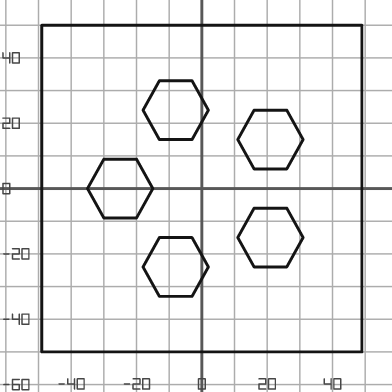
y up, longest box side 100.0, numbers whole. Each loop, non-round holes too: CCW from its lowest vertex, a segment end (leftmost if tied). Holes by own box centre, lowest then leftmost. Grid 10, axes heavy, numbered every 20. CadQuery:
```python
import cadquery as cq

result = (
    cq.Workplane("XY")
    .moveTo(-49.0, -50.0)
    .lineTo(49.0, -50.0)
    .lineTo(49.0, 50.0)
    .lineTo(-49.0, 50.0)
    .close()
    .moveTo(-13.0, -33.0)
    .lineTo(-3.0, -33.0)
    .lineTo(2.0, -24.0)
    .lineTo(-3.0, -15.0)
    .lineTo(-13.0, -15.0)
    .lineTo(-18.0, -24.0)
    .close()
    .moveTo(16.0, -24.0)
    .lineTo(26.0, -24.0)
    .lineTo(31.0, -15.0)
    .lineTo(26.0, -6.0)
    .lineTo(16.0, -6.0)
    .lineTo(11.0, -15.0)
    .close()
    .moveTo(-30.0, -9.0)
    .lineTo(-20.0, -9.0)
    .lineTo(-15.0, 0.0)
    .lineTo(-20.0, 9.0)
    .lineTo(-30.0, 9.0)
    .lineTo(-35.0, 0.0)
    .close()
    .moveTo(16.0, 6.0)
    .lineTo(26.0, 6.0)
    .lineTo(31.0, 15.0)
    .lineTo(26.0, 24.0)
    .lineTo(16.0, 24.0)
    .lineTo(11.0, 15.0)
    .close()
    .moveTo(-13.0, 15.0)
    .lineTo(-3.0, 15.0)
    .lineTo(2.0, 24.0)
    .lineTo(-3.0, 33.0)
    .lineTo(-13.0, 33.0)
    .lineTo(-18.0, 24.0)
    .close()
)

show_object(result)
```